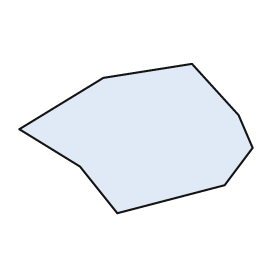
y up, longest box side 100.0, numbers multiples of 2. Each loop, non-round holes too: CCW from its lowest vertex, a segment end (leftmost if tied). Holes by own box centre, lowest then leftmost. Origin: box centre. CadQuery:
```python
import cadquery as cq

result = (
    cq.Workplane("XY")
    .moveTo(-8.0, -32.0)
    .lineTo(38.0, -20.0)
    .lineTo(50.0, -4.0)
    .lineTo(44.0, 10.0)
    .lineTo(24.0, 32.0)
    .lineTo(-14.0, 26.0)
    .lineTo(-50.0, 4.0)
    .lineTo(-24.0, -12.0)
    .close()
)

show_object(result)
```